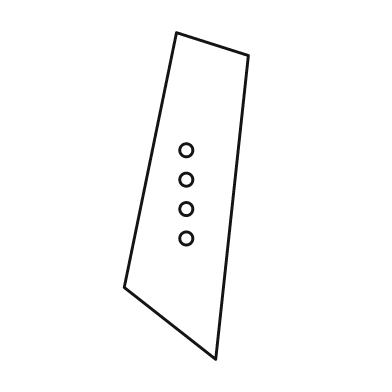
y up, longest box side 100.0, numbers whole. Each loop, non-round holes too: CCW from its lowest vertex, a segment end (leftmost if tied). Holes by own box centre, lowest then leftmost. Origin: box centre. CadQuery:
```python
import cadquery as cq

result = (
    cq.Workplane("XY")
    .moveTo(9.0, -50.0)
    .lineTo(19.0, 43.0)
    .lineTo(-3.0, 50.0)
    .lineTo(-19.0, -28.0)
    .close()
    .moveTo(0.0, -13.0)
    .circle(2.0)
    .moveTo(0.0, -4.0)
    .circle(2.0)
    .moveTo(0.0, 5.0)
    .circle(2.0)
    .moveTo(0.0, 14.0)
    .circle(2.0)
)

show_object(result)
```